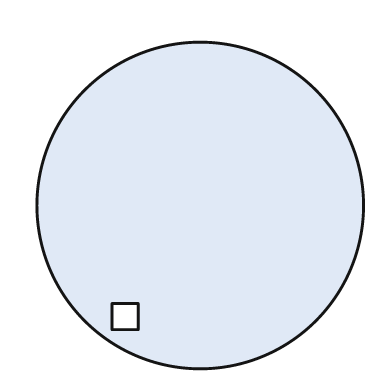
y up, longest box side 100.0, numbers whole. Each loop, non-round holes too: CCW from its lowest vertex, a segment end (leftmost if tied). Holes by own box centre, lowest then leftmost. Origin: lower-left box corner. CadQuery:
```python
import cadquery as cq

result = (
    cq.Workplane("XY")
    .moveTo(50.0, 50.0)
    .circle(50.0)
    .moveTo(23.0, 12.0)
    .lineTo(31.0, 12.0)
    .lineTo(31.0, 20.0)
    .lineTo(23.0, 20.0)
    .close()
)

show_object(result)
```